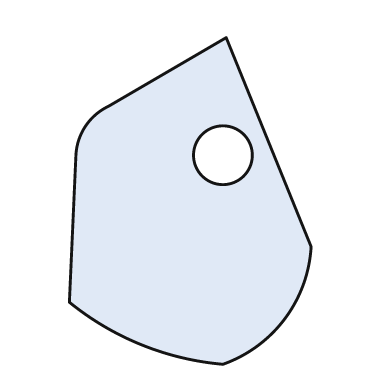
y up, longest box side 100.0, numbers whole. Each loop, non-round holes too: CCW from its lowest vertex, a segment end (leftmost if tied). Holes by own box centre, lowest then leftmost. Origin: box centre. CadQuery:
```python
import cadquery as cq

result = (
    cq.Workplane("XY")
    .moveTo(10.0, -50.0)
    .threePointArc((29.0, -36.0), (37.0, -14.0))
    .lineTo(11.0, 50.0)
    .lineTo(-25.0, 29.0)
    .threePointArc((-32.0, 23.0), (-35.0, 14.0))
    .lineTo(-37.0, -31.0)
    .threePointArc((-15.0, -44.0), (10.0, -50.0))
    .close()
    .moveTo(10.0, 14.0)
    .circle(9.0)
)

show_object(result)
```